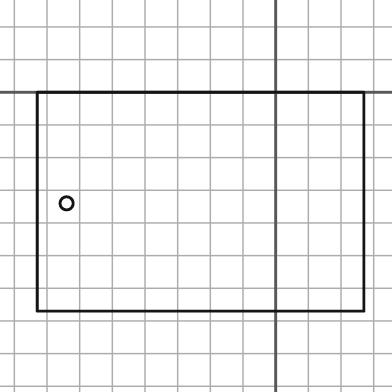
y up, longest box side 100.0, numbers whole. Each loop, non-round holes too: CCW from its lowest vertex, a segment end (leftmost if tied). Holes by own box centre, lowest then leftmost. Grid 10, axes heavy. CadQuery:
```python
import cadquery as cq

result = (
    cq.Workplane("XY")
    .moveTo(-73.0, -67.0)
    .lineTo(27.0, -67.0)
    .lineTo(27.0, 0.0)
    .lineTo(-73.0, 0.0)
    .close()
    .moveTo(-64.0, -34.0)
    .circle(2.0)
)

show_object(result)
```